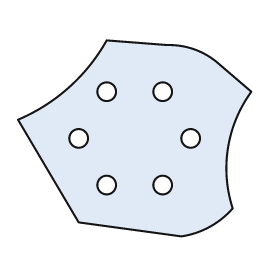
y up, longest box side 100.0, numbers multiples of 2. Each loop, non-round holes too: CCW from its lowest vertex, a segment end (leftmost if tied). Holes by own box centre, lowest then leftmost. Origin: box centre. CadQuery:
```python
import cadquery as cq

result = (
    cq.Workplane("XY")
    .moveTo(20.0, -42.0)
    .threePointArc((32.0, -38.0), (42.0, -30.0))
    .threePointArc((40.0, -4.0), (50.0, 20.0))
    .lineTo(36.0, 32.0)
    .threePointArc((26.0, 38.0), (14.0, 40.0))
    .lineTo(-12.0, 42.0)
    .threePointArc((-28.0, 22.0), (-50.0, 8.0))
    .lineTo(-24.0, -36.0)
    .close()
    .moveTo(-12.0, -20.0)
    .circle(4.0)
    .moveTo(12.0, -20.0)
    .circle(4.0)
    .moveTo(-24.0, 0.0)
    .circle(4.0)
    .moveTo(24.0, 0.0)
    .circle(4.0)
    .moveTo(-12.0, 20.0)
    .circle(4.0)
    .moveTo(12.0, 20.0)
    .circle(4.0)
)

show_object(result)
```